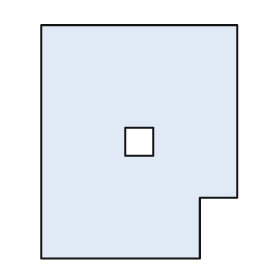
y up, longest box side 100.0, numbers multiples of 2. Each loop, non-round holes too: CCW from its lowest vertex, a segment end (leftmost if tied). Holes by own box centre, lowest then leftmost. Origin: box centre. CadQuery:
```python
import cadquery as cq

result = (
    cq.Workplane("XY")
    .moveTo(-42.0, -50.0)
    .lineTo(26.0, -50.0)
    .lineTo(26.0, -24.0)
    .lineTo(42.0, -24.0)
    .lineTo(42.0, 50.0)
    .lineTo(-42.0, 50.0)
    .close()
    .moveTo(-6.0, -6.0)
    .lineTo(6.0, -6.0)
    .lineTo(6.0, 6.0)
    .lineTo(-6.0, 6.0)
    .close()
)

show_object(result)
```